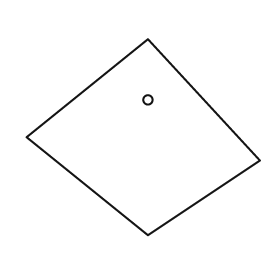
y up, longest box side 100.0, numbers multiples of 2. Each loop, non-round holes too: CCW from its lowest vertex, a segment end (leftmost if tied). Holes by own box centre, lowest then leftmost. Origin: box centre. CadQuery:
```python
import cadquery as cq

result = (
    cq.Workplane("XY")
    .moveTo(2.0, -42.0)
    .lineTo(50.0, -10.0)
    .lineTo(2.0, 42.0)
    .lineTo(-50.0, 0.0)
    .close()
    .moveTo(2.0, 16.0)
    .circle(2.0)
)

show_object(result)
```